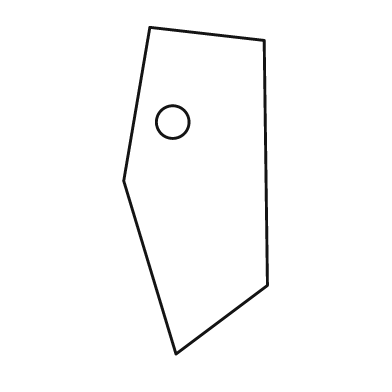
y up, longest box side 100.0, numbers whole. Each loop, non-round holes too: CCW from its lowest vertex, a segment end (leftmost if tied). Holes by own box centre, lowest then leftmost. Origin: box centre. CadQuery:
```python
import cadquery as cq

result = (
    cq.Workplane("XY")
    .moveTo(-6.0, -50.0)
    .lineTo(22.0, -29.0)
    .lineTo(21.0, 46.0)
    .lineTo(-14.0, 50.0)
    .lineTo(-22.0, 3.0)
    .close()
    .moveTo(-7.0, 21.0)
    .circle(5.0)
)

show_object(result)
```